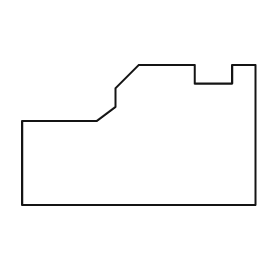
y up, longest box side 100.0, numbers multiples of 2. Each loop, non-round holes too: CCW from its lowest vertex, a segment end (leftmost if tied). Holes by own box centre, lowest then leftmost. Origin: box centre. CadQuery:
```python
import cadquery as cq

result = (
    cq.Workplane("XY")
    .moveTo(-50.0, -30.0)
    .lineTo(50.0, -30.0)
    .lineTo(50.0, 30.0)
    .lineTo(40.0, 30.0)
    .lineTo(40.0, 22.0)
    .lineTo(24.0, 22.0)
    .lineTo(24.0, 30.0)
    .lineTo(0.0, 30.0)
    .lineTo(-10.0, 20.0)
    .lineTo(-10.0, 12.0)
    .lineTo(-18.0, 6.0)
    .lineTo(-50.0, 6.0)
    .close()
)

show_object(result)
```